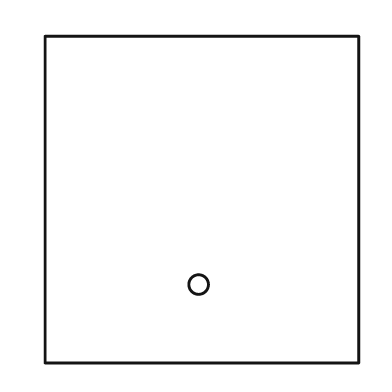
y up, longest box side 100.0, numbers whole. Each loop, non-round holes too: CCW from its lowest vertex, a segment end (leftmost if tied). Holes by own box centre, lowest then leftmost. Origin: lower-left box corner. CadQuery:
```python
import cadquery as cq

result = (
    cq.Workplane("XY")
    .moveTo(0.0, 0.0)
    .lineTo(96.0, 0.0)
    .lineTo(96.0, 100.0)
    .lineTo(0.0, 100.0)
    .close()
    .moveTo(47.0, 24.0)
    .circle(3.0)
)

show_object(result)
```